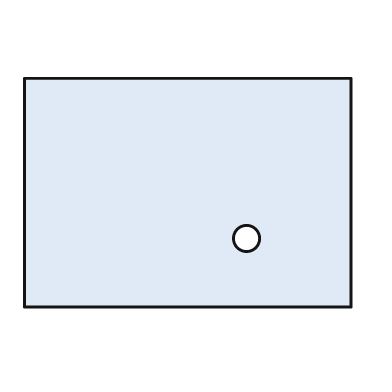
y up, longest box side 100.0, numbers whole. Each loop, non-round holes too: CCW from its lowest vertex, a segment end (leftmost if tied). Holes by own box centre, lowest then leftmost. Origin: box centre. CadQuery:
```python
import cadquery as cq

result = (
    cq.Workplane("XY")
    .moveTo(-50.0, -35.0)
    .lineTo(50.0, -35.0)
    .lineTo(50.0, 35.0)
    .lineTo(-50.0, 35.0)
    .close()
    .moveTo(18.0, -14.0)
    .circle(4.0)
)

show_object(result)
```